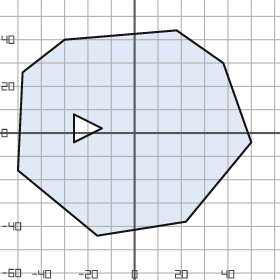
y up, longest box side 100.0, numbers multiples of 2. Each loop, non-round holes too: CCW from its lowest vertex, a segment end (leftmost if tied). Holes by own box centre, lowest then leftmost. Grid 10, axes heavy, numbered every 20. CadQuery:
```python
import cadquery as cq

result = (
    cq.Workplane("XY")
    .moveTo(-16.0, -44.0)
    .lineTo(22.0, -38.0)
    .lineTo(50.0, -4.0)
    .lineTo(38.0, 30.0)
    .lineTo(18.0, 44.0)
    .lineTo(-30.0, 40.0)
    .lineTo(-48.0, 26.0)
    .lineTo(-50.0, -16.0)
    .close()
    .moveTo(-26.0, -4.0)
    .lineTo(-14.0, 2.0)
    .lineTo(-26.0, 8.0)
    .close()
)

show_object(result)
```